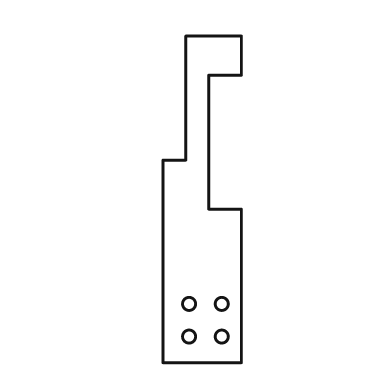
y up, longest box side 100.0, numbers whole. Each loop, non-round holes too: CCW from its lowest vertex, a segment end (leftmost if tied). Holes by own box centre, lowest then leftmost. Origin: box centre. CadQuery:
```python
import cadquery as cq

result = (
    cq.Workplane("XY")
    .moveTo(-12.0, -50.0)
    .lineTo(12.0, -50.0)
    .lineTo(12.0, -3.0)
    .lineTo(2.0, -3.0)
    .lineTo(2.0, 38.0)
    .lineTo(12.0, 38.0)
    .lineTo(12.0, 50.0)
    .lineTo(-5.0, 50.0)
    .lineTo(-5.0, 12.0)
    .lineTo(-12.0, 12.0)
    .close()
    .moveTo(-4.0, -42.0)
    .circle(2.0)
    .moveTo(6.0, -42.0)
    .circle(2.0)
    .moveTo(-4.0, -32.0)
    .circle(2.0)
    .moveTo(6.0, -32.0)
    .circle(2.0)
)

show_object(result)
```